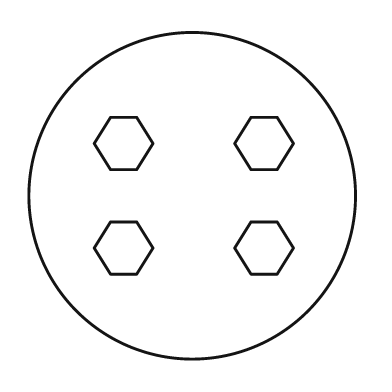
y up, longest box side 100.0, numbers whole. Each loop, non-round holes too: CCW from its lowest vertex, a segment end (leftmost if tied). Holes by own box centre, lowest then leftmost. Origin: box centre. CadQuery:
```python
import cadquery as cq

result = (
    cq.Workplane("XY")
    .moveTo(0.0, 0.0)
    .circle(50.0)
    .moveTo(-25.0, -24.0)
    .lineTo(-17.0, -24.0)
    .lineTo(-12.0, -16.0)
    .lineTo(-17.0, -8.0)
    .lineTo(-25.0, -8.0)
    .lineTo(-30.0, -16.0)
    .close()
    .moveTo(18.0, -24.0)
    .lineTo(26.0, -24.0)
    .lineTo(31.0, -16.0)
    .lineTo(26.0, -8.0)
    .lineTo(18.0, -8.0)
    .lineTo(13.0, -16.0)
    .close()
    .moveTo(-25.0, 8.0)
    .lineTo(-17.0, 8.0)
    .lineTo(-12.0, 16.0)
    .lineTo(-17.0, 24.0)
    .lineTo(-25.0, 24.0)
    .lineTo(-30.0, 16.0)
    .close()
    .moveTo(18.0, 8.0)
    .lineTo(26.0, 8.0)
    .lineTo(31.0, 16.0)
    .lineTo(26.0, 24.0)
    .lineTo(18.0, 24.0)
    .lineTo(13.0, 16.0)
    .close()
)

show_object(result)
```